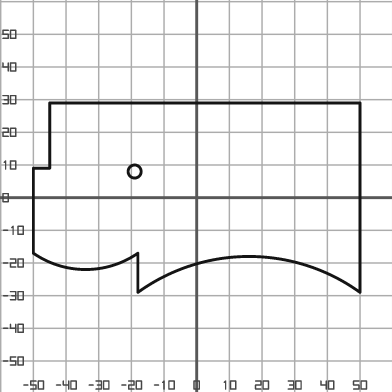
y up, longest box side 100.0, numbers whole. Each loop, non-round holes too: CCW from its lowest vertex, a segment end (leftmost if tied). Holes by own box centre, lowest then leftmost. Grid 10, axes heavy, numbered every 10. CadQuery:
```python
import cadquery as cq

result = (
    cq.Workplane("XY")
    .moveTo(-18.0, -29.0)
    .threePointArc((16.0, -18.0), (50.0, -29.0))
    .lineTo(50.0, 29.0)
    .lineTo(-45.0, 29.0)
    .lineTo(-45.0, 9.0)
    .lineTo(-50.0, 9.0)
    .lineTo(-50.0, -17.0)
    .threePointArc((-34.0, -22.0), (-18.0, -17.0))
    .close()
    .moveTo(-19.0, 8.0)
    .circle(2.0)
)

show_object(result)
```